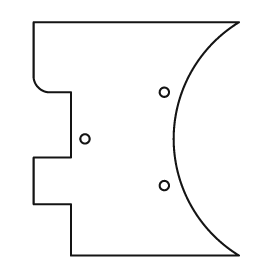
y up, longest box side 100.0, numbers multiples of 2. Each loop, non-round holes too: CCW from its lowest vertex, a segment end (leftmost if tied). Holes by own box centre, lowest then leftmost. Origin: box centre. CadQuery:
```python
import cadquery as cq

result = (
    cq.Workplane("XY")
    .moveTo(-28.0, -50.0)
    .lineTo(44.0, -50.0)
    .threePointArc((16.0, 0.0), (44.0, 50.0))
    .lineTo(-44.0, 50.0)
    .lineTo(-44.0, 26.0)
    .threePointArc((-42.0, 22.0), (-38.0, 20.0))
    .lineTo(-28.0, 20.0)
    .lineTo(-28.0, -8.0)
    .lineTo(-44.0, -8.0)
    .lineTo(-44.0, -28.0)
    .lineTo(-28.0, -28.0)
    .close()
    .moveTo(12.0, -20.0)
    .circle(2.0)
    .moveTo(-22.0, 0.0)
    .circle(2.0)
    .moveTo(12.0, 20.0)
    .circle(2.0)
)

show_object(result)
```